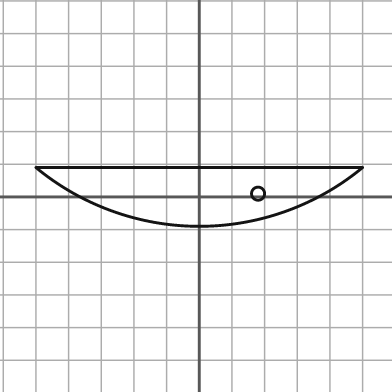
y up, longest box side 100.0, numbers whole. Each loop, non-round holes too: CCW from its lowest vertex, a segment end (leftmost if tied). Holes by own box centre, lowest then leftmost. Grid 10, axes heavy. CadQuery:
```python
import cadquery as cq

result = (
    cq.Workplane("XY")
    .moveTo(-50.0, 9.0)
    .threePointArc((0.0, -9.0), (50.0, 9.0))
    .close()
    .moveTo(18.0, 1.0)
    .circle(2.0)
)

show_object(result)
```